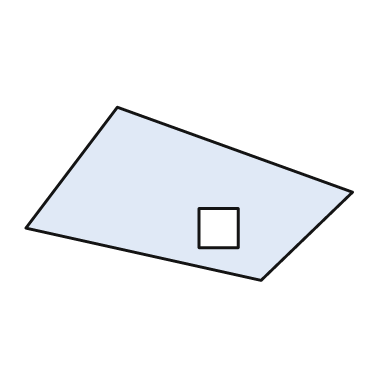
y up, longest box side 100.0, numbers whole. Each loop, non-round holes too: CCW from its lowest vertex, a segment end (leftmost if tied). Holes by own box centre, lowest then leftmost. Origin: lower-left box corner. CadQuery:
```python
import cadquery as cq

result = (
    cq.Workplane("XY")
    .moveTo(72.0, 0.0)
    .lineTo(100.0, 27.0)
    .lineTo(28.0, 53.0)
    .lineTo(0.0, 16.0)
    .close()
    .moveTo(53.0, 10.0)
    .lineTo(65.0, 10.0)
    .lineTo(65.0, 22.0)
    .lineTo(53.0, 22.0)
    .close()
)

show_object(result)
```